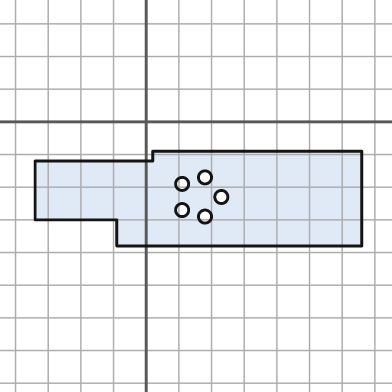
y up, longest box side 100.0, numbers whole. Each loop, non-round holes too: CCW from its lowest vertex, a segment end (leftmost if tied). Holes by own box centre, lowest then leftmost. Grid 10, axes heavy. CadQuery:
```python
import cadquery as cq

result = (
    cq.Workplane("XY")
    .moveTo(-9.0, -38.0)
    .lineTo(66.0, -38.0)
    .lineTo(66.0, -9.0)
    .lineTo(2.0, -9.0)
    .lineTo(2.0, -12.0)
    .lineTo(-34.0, -12.0)
    .lineTo(-34.0, -30.0)
    .lineTo(-9.0, -30.0)
    .close()
    .moveTo(18.0, -29.0)
    .circle(2.0)
    .moveTo(11.0, -27.0)
    .circle(2.0)
    .moveTo(23.0, -23.0)
    .circle(2.0)
    .moveTo(11.0, -19.0)
    .circle(2.0)
    .moveTo(18.0, -17.0)
    .circle(2.0)
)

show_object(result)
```